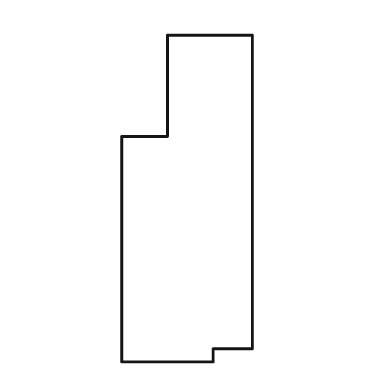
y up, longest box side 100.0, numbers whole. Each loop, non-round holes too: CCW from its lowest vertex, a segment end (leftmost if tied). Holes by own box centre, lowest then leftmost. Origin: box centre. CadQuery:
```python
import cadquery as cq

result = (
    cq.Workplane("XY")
    .moveTo(-20.0, -50.0)
    .lineTo(8.0, -50.0)
    .lineTo(8.0, -46.0)
    .lineTo(20.0, -46.0)
    .lineTo(20.0, 50.0)
    .lineTo(-6.0, 50.0)
    .lineTo(-6.0, 19.0)
    .lineTo(-20.0, 19.0)
    .close()
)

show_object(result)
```